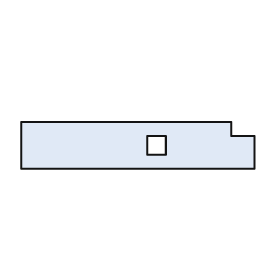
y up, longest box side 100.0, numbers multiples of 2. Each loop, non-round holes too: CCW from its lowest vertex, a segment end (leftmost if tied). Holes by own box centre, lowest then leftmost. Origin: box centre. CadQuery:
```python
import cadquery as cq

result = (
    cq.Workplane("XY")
    .moveTo(-50.0, -10.0)
    .lineTo(50.0, -10.0)
    .lineTo(50.0, 4.0)
    .lineTo(40.0, 4.0)
    .lineTo(40.0, 10.0)
    .lineTo(-50.0, 10.0)
    .close()
    .moveTo(4.0, -4.0)
    .lineTo(12.0, -4.0)
    .lineTo(12.0, 4.0)
    .lineTo(4.0, 4.0)
    .close()
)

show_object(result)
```